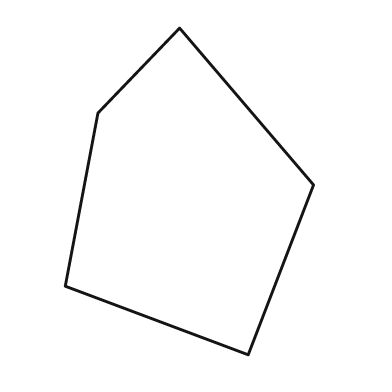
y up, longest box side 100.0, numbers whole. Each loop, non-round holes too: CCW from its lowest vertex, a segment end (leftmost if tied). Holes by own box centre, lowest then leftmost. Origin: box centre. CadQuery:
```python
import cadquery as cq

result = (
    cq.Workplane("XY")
    .moveTo(18.0, -50.0)
    .lineTo(38.0, 2.0)
    .lineTo(-3.0, 50.0)
    .lineTo(-28.0, 24.0)
    .lineTo(-38.0, -29.0)
    .close()
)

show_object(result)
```